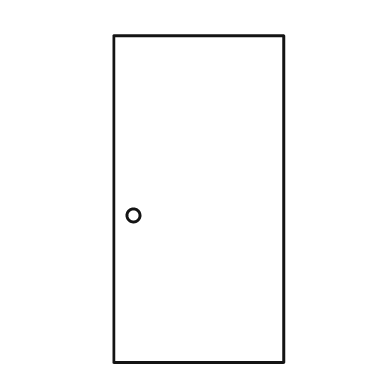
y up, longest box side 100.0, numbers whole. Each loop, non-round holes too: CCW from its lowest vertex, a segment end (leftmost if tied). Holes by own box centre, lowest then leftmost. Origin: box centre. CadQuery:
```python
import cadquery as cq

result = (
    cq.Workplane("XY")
    .moveTo(-26.0, -50.0)
    .lineTo(26.0, -50.0)
    .lineTo(26.0, 50.0)
    .lineTo(-26.0, 50.0)
    .close()
    .moveTo(-20.0, -5.0)
    .circle(2.0)
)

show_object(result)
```